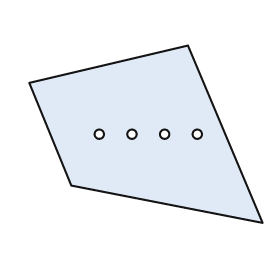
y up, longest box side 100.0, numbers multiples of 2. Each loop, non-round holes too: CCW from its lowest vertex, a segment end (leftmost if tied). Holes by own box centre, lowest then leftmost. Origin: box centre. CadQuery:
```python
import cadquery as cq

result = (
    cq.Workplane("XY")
    .moveTo(50.0, -38.0)
    .lineTo(18.0, 38.0)
    .lineTo(-50.0, 22.0)
    .lineTo(-32.0, -22.0)
    .close()
    .moveTo(-20.0, 0.0)
    .circle(2.0)
    .moveTo(-6.0, 0.0)
    .circle(2.0)
    .moveTo(8.0, 0.0)
    .circle(2.0)
    .moveTo(22.0, 0.0)
    .circle(2.0)
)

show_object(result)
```